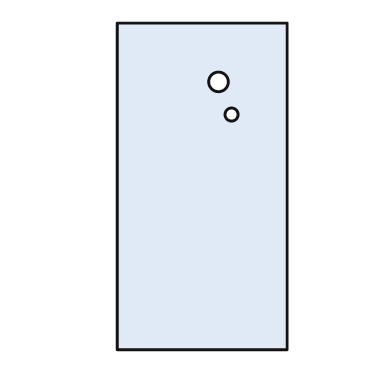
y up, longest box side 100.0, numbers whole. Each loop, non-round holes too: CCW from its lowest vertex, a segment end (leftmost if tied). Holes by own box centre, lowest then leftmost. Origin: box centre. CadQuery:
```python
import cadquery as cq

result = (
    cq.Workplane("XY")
    .moveTo(-26.0, -50.0)
    .lineTo(26.0, -50.0)
    .lineTo(26.0, 50.0)
    .lineTo(-26.0, 50.0)
    .close()
    .moveTo(9.0, 22.0)
    .circle(2.0)
    .moveTo(5.0, 32.0)
    .circle(3.0)
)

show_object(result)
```